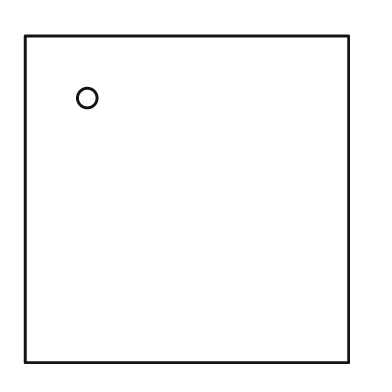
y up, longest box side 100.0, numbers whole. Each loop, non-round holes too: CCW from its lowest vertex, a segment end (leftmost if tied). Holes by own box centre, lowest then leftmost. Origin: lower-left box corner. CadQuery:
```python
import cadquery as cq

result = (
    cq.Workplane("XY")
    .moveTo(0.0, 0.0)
    .lineTo(99.0, 0.0)
    .lineTo(99.0, 100.0)
    .lineTo(0.0, 100.0)
    .close()
    .moveTo(19.0, 81.0)
    .circle(3.0)
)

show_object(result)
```